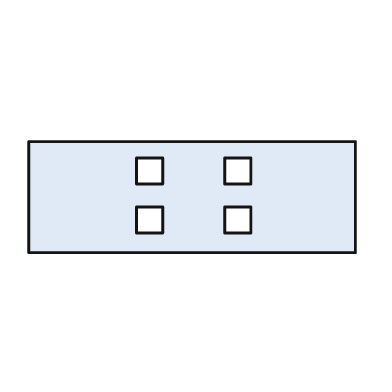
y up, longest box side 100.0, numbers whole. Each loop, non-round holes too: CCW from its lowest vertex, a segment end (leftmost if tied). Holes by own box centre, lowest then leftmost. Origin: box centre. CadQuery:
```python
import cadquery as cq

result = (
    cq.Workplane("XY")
    .moveTo(-50.0, -17.0)
    .lineTo(50.0, -17.0)
    .lineTo(50.0, 17.0)
    .lineTo(-50.0, 17.0)
    .close()
    .moveTo(-17.0, -11.0)
    .lineTo(-9.0, -11.0)
    .lineTo(-9.0, -3.0)
    .lineTo(-17.0, -3.0)
    .close()
    .moveTo(10.0, -11.0)
    .lineTo(18.0, -11.0)
    .lineTo(18.0, -3.0)
    .lineTo(10.0, -3.0)
    .close()
    .moveTo(-17.0, 4.0)
    .lineTo(-9.0, 4.0)
    .lineTo(-9.0, 12.0)
    .lineTo(-17.0, 12.0)
    .close()
    .moveTo(10.0, 4.0)
    .lineTo(18.0, 4.0)
    .lineTo(18.0, 12.0)
    .lineTo(10.0, 12.0)
    .close()
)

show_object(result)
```